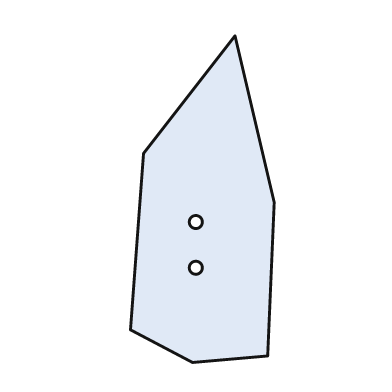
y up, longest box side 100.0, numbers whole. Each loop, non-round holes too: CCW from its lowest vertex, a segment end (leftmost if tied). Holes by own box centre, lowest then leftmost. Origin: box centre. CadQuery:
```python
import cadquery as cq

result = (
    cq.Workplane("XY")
    .moveTo(-3.0, -50.0)
    .lineTo(20.0, -48.0)
    .lineTo(22.0, -1.0)
    .lineTo(10.0, 50.0)
    .lineTo(-18.0, 14.0)
    .lineTo(-22.0, -40.0)
    .close()
    .moveTo(-2.0, -21.0)
    .circle(2.0)
    .moveTo(-2.0, -7.0)
    .circle(2.0)
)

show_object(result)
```